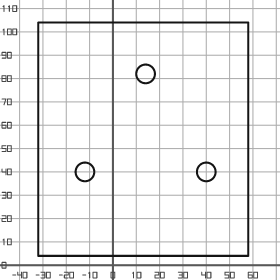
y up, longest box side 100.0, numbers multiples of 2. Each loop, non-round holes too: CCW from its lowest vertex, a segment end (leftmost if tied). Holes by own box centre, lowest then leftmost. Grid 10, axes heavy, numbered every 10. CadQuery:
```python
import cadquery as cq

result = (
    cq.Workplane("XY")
    .moveTo(-32.0, 4.0)
    .lineTo(58.0, 4.0)
    .lineTo(58.0, 104.0)
    .lineTo(-32.0, 104.0)
    .close()
    .moveTo(-12.0, 40.0)
    .circle(4.0)
    .moveTo(40.0, 40.0)
    .circle(4.0)
    .moveTo(14.0, 82.0)
    .circle(4.0)
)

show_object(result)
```